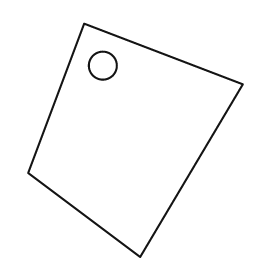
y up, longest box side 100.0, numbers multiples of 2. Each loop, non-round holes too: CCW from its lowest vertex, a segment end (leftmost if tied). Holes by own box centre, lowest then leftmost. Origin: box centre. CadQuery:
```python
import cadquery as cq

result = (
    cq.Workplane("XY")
    .moveTo(2.0, -50.0)
    .lineTo(46.0, 24.0)
    .lineTo(-22.0, 50.0)
    .lineTo(-46.0, -14.0)
    .close()
    .moveTo(-14.0, 32.0)
    .circle(6.0)
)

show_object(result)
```